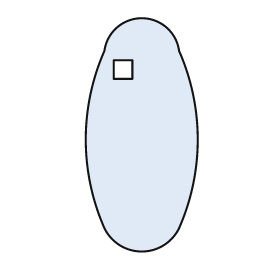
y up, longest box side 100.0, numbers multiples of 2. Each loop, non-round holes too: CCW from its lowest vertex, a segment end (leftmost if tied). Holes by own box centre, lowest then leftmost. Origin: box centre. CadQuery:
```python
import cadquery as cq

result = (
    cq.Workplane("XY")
    .moveTo(-16.0, -40.0)
    .threePointArc((0.0, -50.0), (16.0, -40.0))
    .threePointArc((24.0, -2.0), (16.0, 36.0))
    .threePointArc((0.0, 50.0), (-16.0, 36.0))
    .threePointArc((-24.0, -2.0), (-16.0, -40.0))
    .close()
    .moveTo(-12.0, 24.0)
    .lineTo(-4.0, 24.0)
    .lineTo(-4.0, 32.0)
    .lineTo(-12.0, 32.0)
    .close()
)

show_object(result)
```